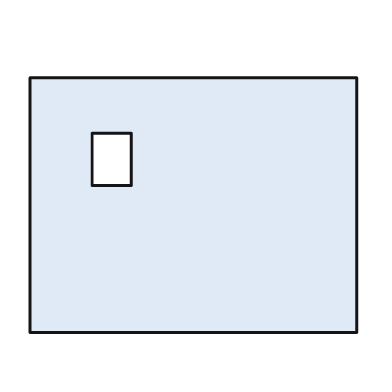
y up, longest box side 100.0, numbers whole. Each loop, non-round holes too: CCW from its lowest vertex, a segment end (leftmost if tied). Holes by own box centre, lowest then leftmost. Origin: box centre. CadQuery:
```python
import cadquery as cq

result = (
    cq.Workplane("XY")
    .moveTo(-50.0, -39.0)
    .lineTo(50.0, -39.0)
    .lineTo(50.0, 39.0)
    .lineTo(-50.0, 39.0)
    .close()
    .moveTo(-31.0, 6.0)
    .lineTo(-19.0, 6.0)
    .lineTo(-19.0, 22.0)
    .lineTo(-31.0, 22.0)
    .close()
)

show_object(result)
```